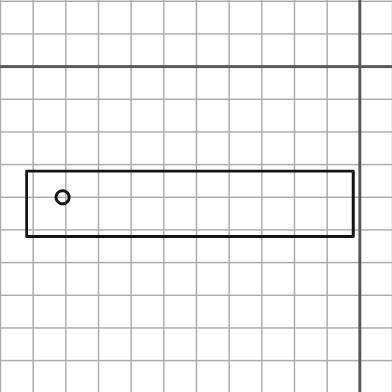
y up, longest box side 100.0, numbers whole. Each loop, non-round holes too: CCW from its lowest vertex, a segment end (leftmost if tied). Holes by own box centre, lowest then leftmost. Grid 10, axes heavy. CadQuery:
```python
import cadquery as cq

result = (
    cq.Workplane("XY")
    .moveTo(-102.0, -52.0)
    .lineTo(-2.0, -52.0)
    .lineTo(-2.0, -32.0)
    .lineTo(-102.0, -32.0)
    .close()
    .moveTo(-91.0, -40.0)
    .circle(2.0)
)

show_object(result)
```